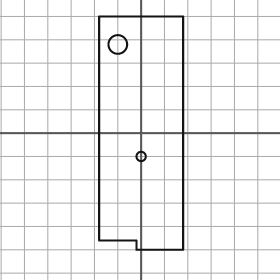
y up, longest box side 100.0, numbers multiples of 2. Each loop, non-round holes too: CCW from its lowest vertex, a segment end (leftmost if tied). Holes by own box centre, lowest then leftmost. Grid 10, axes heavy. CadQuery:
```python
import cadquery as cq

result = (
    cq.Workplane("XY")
    .moveTo(-2.0, -50.0)
    .lineTo(18.0, -50.0)
    .lineTo(18.0, 50.0)
    .lineTo(-18.0, 50.0)
    .lineTo(-18.0, -46.0)
    .lineTo(-2.0, -46.0)
    .close()
    .moveTo(0.0, -10.0)
    .circle(2.0)
    .moveTo(-10.0, 38.0)
    .circle(4.0)
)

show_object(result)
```